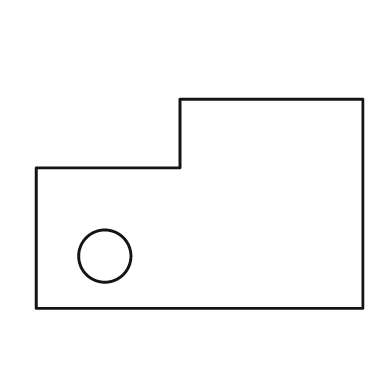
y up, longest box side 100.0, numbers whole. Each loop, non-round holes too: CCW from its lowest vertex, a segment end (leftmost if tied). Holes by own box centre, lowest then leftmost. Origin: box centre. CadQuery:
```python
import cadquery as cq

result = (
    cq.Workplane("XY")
    .moveTo(-50.0, -32.0)
    .lineTo(50.0, -32.0)
    .lineTo(50.0, 32.0)
    .lineTo(-6.0, 32.0)
    .lineTo(-6.0, 11.0)
    .lineTo(-50.0, 11.0)
    .close()
    .moveTo(-29.0, -16.0)
    .circle(8.0)
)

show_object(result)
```